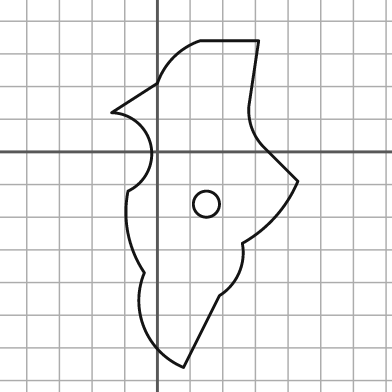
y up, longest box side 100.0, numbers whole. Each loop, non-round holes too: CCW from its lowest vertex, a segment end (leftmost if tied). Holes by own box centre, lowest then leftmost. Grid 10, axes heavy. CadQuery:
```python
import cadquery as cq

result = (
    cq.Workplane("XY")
    .moveTo(8.0, -66.0)
    .lineTo(19.0, -44.0)
    .threePointArc((25.0, -37.0), (26.0, -28.0))
    .threePointArc((36.0, -20.0), (43.0, -9.0))
    .lineTo(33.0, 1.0)
    .threePointArc((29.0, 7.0), (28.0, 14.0))
    .lineTo(31.0, 34.0)
    .lineTo(13.0, 34.0)
    .threePointArc((5.0, 29.0), (0.0, 21.0))
    .lineTo(-14.0, 12.0)
    .threePointArc((-2.0, 2.0), (-9.0, -12.0))
    .threePointArc((-9.0, -25.0), (-4.0, -37.0))
    .threePointArc((-4.0, -54.0), (8.0, -66.0))
    .close()
    .moveTo(15.0, -16.0)
    .circle(4.0)
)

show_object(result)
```